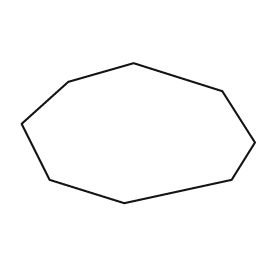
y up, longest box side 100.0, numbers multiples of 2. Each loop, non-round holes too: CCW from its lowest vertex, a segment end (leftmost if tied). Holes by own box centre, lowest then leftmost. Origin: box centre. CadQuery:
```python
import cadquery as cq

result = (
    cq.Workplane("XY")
    .moveTo(-6.0, -30.0)
    .lineTo(40.0, -20.0)
    .lineTo(50.0, -4.0)
    .lineTo(36.0, 18.0)
    .lineTo(-2.0, 30.0)
    .lineTo(-30.0, 22.0)
    .lineTo(-50.0, 4.0)
    .lineTo(-38.0, -20.0)
    .close()
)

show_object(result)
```